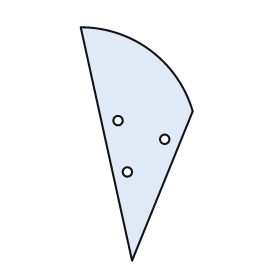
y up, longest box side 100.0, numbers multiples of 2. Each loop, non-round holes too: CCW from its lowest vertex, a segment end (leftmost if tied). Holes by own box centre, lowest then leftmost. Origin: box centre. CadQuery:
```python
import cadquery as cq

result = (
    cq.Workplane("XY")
    .moveTo(-2.0, -50.0)
    .lineTo(24.0, 14.0)
    .threePointArc((6.0, 40.0), (-24.0, 50.0))
    .close()
    .moveTo(-4.0, -12.0)
    .circle(2.0)
    .moveTo(12.0, 2.0)
    .circle(2.0)
    .moveTo(-8.0, 10.0)
    .circle(2.0)
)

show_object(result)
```